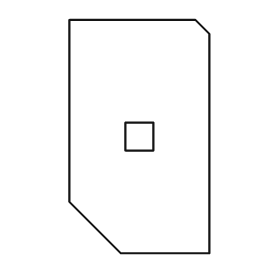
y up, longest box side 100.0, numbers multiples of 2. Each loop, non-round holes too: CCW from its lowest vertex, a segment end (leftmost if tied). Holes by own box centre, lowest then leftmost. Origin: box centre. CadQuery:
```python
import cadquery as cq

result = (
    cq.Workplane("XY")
    .moveTo(-8.0, -50.0)
    .lineTo(30.0, -50.0)
    .lineTo(30.0, 44.0)
    .lineTo(24.0, 50.0)
    .lineTo(-30.0, 50.0)
    .lineTo(-30.0, -28.0)
    .close()
    .moveTo(-6.0, -6.0)
    .lineTo(6.0, -6.0)
    .lineTo(6.0, 6.0)
    .lineTo(-6.0, 6.0)
    .close()
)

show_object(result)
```